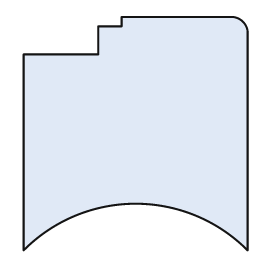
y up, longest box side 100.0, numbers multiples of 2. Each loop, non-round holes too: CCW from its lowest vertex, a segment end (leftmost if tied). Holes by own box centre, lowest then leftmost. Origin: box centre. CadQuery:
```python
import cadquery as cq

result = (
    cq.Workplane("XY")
    .moveTo(-48.0, -50.0)
    .threePointArc((0.0, -30.0), (48.0, -50.0))
    .lineTo(48.0, 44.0)
    .threePointArc((46.0, 48.0), (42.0, 50.0))
    .lineTo(-6.0, 50.0)
    .lineTo(-6.0, 46.0)
    .lineTo(-16.0, 46.0)
    .lineTo(-16.0, 34.0)
    .lineTo(-48.0, 34.0)
    .close()
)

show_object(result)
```